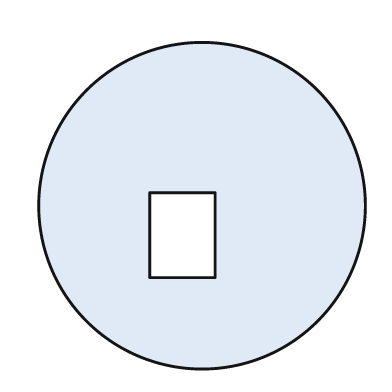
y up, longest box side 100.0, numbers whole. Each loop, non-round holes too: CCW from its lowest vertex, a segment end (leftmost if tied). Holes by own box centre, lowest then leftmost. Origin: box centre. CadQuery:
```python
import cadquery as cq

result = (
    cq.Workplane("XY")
    .moveTo(0.0, 0.0)
    .circle(50.0)
    .moveTo(-16.0, -22.0)
    .lineTo(4.0, -22.0)
    .lineTo(4.0, 4.0)
    .lineTo(-16.0, 4.0)
    .close()
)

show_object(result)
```